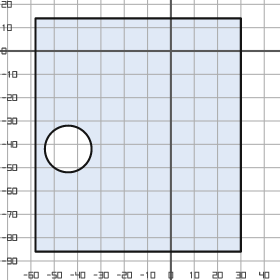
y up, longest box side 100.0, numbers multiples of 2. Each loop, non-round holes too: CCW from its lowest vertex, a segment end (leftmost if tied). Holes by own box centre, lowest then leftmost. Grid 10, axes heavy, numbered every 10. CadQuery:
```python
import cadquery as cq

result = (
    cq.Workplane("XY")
    .moveTo(-58.0, -86.0)
    .lineTo(30.0, -86.0)
    .lineTo(30.0, 14.0)
    .lineTo(-58.0, 14.0)
    .close()
    .moveTo(-44.0, -42.0)
    .circle(10.0)
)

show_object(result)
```